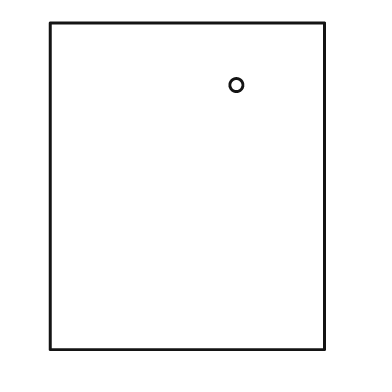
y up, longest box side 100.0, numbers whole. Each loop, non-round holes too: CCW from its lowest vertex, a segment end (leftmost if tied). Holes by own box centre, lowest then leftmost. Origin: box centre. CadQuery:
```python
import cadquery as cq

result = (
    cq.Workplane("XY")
    .moveTo(-42.0, -50.0)
    .lineTo(42.0, -50.0)
    .lineTo(42.0, 50.0)
    .lineTo(-42.0, 50.0)
    .close()
    .moveTo(15.0, 31.0)
    .circle(2.0)
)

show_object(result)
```